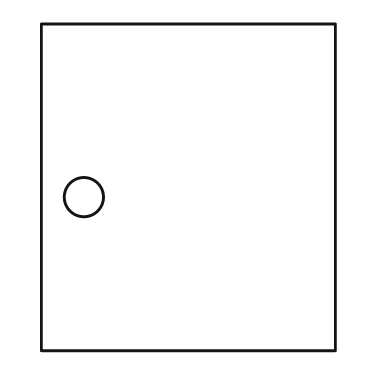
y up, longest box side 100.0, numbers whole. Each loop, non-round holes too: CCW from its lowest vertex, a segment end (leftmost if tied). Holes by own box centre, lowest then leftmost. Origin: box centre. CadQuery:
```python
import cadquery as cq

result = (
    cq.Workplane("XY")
    .moveTo(-45.0, -50.0)
    .lineTo(45.0, -50.0)
    .lineTo(45.0, 50.0)
    .lineTo(-45.0, 50.0)
    .close()
    .moveTo(-32.0, -3.0)
    .circle(6.0)
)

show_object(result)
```